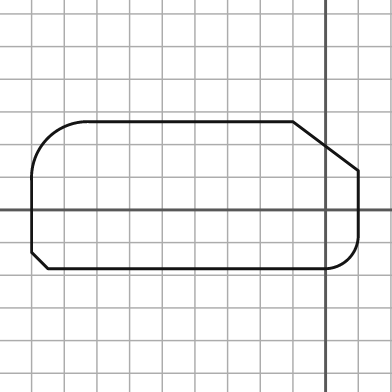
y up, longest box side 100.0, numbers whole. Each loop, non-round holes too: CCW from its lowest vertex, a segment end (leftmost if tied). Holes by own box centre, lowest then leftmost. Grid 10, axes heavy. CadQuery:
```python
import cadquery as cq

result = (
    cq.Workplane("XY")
    .moveTo(-85.0, -18.0)
    .lineTo(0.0, -18.0)
    .threePointArc((7.0, -15.0), (10.0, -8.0))
    .lineTo(10.0, 12.0)
    .lineTo(-10.0, 27.0)
    .lineTo(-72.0, 27.0)
    .threePointArc((-85.0, 22.0), (-90.0, 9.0))
    .lineTo(-90.0, -13.0)
    .close()
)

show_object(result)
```